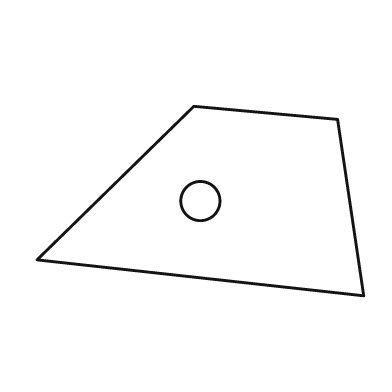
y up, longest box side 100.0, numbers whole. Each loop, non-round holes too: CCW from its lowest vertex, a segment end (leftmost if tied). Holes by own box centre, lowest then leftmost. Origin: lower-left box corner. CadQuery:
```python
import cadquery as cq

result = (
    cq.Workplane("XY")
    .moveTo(100.0, 0.0)
    .lineTo(92.0, 54.0)
    .lineTo(48.0, 58.0)
    .lineTo(0.0, 11.0)
    .close()
    .moveTo(50.0, 29.0)
    .circle(6.0)
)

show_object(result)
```